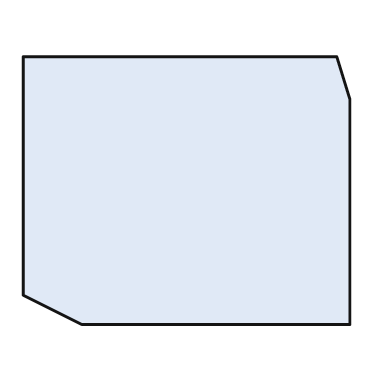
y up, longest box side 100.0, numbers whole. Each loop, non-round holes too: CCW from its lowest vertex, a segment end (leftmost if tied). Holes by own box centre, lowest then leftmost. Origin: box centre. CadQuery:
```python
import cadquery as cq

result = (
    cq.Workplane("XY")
    .moveTo(-32.0, -41.0)
    .lineTo(50.0, -41.0)
    .lineTo(50.0, 28.0)
    .lineTo(46.0, 41.0)
    .lineTo(-50.0, 41.0)
    .lineTo(-50.0, -32.0)
    .close()
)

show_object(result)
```